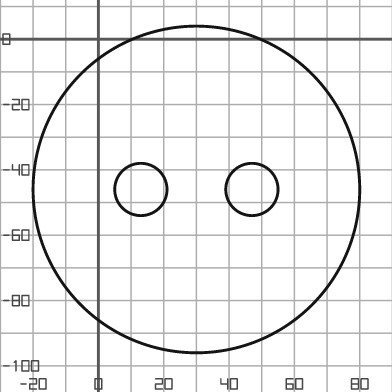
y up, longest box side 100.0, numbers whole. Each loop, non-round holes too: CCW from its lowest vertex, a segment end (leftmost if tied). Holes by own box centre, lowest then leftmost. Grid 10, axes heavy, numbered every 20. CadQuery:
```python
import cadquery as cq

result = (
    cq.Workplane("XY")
    .moveTo(30.0, -46.0)
    .circle(50.0)
    .moveTo(13.0, -46.0)
    .circle(8.0)
    .moveTo(47.0, -46.0)
    .circle(8.0)
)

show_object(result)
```